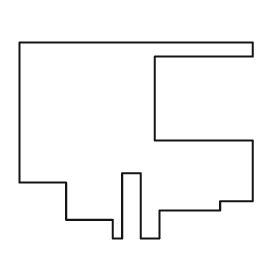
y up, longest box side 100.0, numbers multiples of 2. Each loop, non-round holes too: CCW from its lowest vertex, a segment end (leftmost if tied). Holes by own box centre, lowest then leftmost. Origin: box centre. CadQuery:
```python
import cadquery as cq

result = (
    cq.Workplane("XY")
    .moveTo(-10.0, -42.0)
    .lineTo(-6.0, -42.0)
    .lineTo(-6.0, -14.0)
    .lineTo(2.0, -14.0)
    .lineTo(2.0, -42.0)
    .lineTo(10.0, -42.0)
    .lineTo(10.0, -30.0)
    .lineTo(36.0, -30.0)
    .lineTo(36.0, -26.0)
    .lineTo(50.0, -26.0)
    .lineTo(50.0, 0.0)
    .lineTo(8.0, 0.0)
    .lineTo(8.0, 36.0)
    .lineTo(50.0, 36.0)
    .lineTo(50.0, 42.0)
    .lineTo(-50.0, 42.0)
    .lineTo(-50.0, -18.0)
    .lineTo(-30.0, -18.0)
    .lineTo(-30.0, -34.0)
    .lineTo(-10.0, -34.0)
    .close()
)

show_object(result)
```